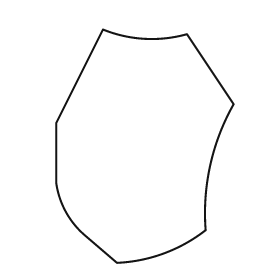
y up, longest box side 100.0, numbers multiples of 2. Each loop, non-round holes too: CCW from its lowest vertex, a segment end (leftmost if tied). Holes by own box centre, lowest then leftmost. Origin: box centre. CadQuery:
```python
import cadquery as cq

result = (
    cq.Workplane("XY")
    .moveTo(-12.0, -50.0)
    .threePointArc((8.0, -46.0), (26.0, -36.0))
    .threePointArc((28.0, -8.0), (38.0, 18.0))
    .lineTo(18.0, 48.0)
    .threePointArc((0.0, 46.0), (-18.0, 50.0))
    .lineTo(-38.0, 10.0)
    .lineTo(-38.0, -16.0)
    .threePointArc((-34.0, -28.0), (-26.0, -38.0))
    .close()
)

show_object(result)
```